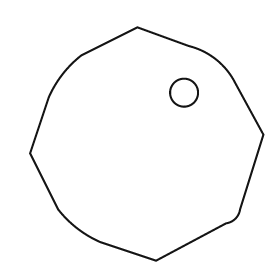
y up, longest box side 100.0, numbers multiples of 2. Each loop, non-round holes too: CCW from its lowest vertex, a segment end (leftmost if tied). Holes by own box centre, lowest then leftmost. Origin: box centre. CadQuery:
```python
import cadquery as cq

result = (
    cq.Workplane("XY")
    .moveTo(4.0, -50.0)
    .lineTo(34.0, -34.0)
    .threePointArc((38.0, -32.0), (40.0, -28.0))
    .lineTo(50.0, 4.0)
    .lineTo(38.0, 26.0)
    .threePointArc((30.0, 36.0), (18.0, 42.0))
    .lineTo(-4.0, 50.0)
    .lineTo(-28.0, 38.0)
    .threePointArc((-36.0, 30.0), (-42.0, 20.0))
    .lineTo(-50.0, -4.0)
    .lineTo(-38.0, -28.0)
    .threePointArc((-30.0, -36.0), (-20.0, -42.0))
    .close()
    .moveTo(16.0, 22.0)
    .circle(6.0)
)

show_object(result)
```